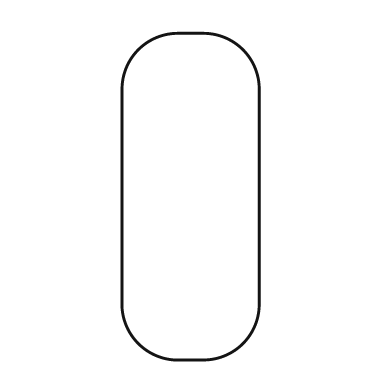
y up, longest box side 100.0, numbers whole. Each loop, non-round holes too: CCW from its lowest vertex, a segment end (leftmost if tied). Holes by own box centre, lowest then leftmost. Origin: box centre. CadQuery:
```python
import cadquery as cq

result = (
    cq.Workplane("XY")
    .moveTo(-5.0, -50.0)
    .lineTo(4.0, -50.0)
    .threePointArc((16.0, -45.0), (21.0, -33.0))
    .lineTo(21.0, 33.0)
    .threePointArc((16.0, 45.0), (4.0, 50.0))
    .lineTo(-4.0, 50.0)
    .threePointArc((-16.0, 45.0), (-21.0, 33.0))
    .lineTo(-21.0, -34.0)
    .threePointArc((-16.0, -45.0), (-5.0, -50.0))
    .close()
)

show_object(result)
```